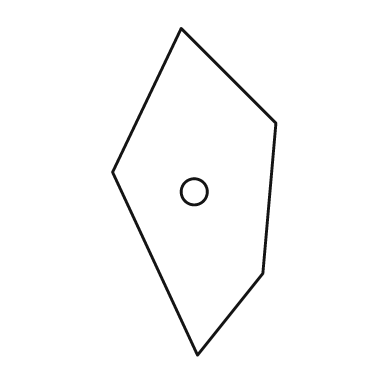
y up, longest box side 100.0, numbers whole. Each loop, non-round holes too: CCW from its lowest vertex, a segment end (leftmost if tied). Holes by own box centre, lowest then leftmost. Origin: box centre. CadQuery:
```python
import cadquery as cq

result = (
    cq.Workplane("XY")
    .moveTo(1.0, -50.0)
    .lineTo(21.0, -25.0)
    .lineTo(25.0, 21.0)
    .lineTo(-4.0, 50.0)
    .lineTo(-25.0, 6.0)
    .close()
    .moveTo(0.0, 0.0)
    .circle(4.0)
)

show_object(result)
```